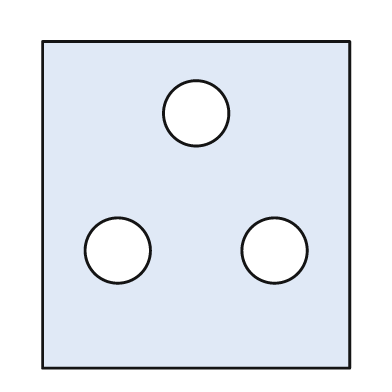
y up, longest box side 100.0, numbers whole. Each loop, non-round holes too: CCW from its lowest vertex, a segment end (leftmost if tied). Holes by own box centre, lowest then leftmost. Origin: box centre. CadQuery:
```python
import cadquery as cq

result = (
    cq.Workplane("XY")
    .moveTo(-47.0, -50.0)
    .lineTo(47.0, -50.0)
    .lineTo(47.0, 50.0)
    .lineTo(-47.0, 50.0)
    .close()
    .moveTo(-24.0, -14.0)
    .circle(10.0)
    .moveTo(24.0, -14.0)
    .circle(10.0)
    .moveTo(0.0, 28.0)
    .circle(10.0)
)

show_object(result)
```